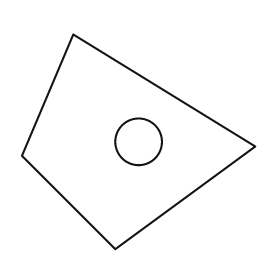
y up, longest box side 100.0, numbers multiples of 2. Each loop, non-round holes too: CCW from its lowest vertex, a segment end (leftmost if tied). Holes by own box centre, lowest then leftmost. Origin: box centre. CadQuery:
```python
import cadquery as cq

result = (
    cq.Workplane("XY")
    .moveTo(-10.0, -46.0)
    .lineTo(50.0, -2.0)
    .lineTo(-28.0, 46.0)
    .lineTo(-50.0, -6.0)
    .close()
    .moveTo(0.0, 0.0)
    .circle(10.0)
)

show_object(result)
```